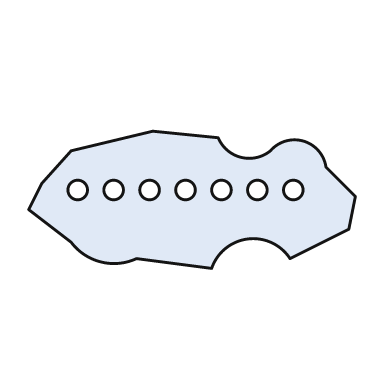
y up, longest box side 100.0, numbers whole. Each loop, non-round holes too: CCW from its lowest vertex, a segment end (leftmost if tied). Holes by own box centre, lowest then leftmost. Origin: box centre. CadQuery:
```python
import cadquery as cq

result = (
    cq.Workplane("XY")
    .moveTo(6.0, -21.0)
    .threePointArc((17.0, -12.0), (30.0, -18.0))
    .lineTo(48.0, -9.0)
    .lineTo(50.0, 1.0)
    .lineTo(41.0, 10.0)
    .threePointArc((34.0, 18.0), (24.0, 15.0))
    .threePointArc((15.0, 13.0), (8.0, 19.0))
    .lineTo(-12.0, 21.0)
    .lineTo(-37.0, 15.0)
    .lineTo(-46.0, 5.0)
    .lineTo(-50.0, -3.0)
    .lineTo(-37.0, -13.0)
    .threePointArc((-28.0, -19.0), (-17.0, -18.0))
    .close()
    .moveTo(-35.0, 3.0)
    .circle(3.0)
    .moveTo(-24.0, 3.0)
    .circle(3.0)
    .moveTo(-13.0, 3.0)
    .circle(3.0)
    .moveTo(-2.0, 3.0)
    .circle(3.0)
    .moveTo(9.0, 3.0)
    .circle(3.0)
    .moveTo(20.0, 3.0)
    .circle(3.0)
    .moveTo(31.0, 3.0)
    .circle(3.0)
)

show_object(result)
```